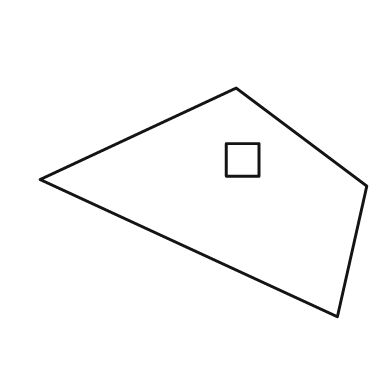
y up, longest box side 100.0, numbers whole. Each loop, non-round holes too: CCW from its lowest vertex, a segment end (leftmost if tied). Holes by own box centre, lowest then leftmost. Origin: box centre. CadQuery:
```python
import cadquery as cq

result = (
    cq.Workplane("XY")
    .moveTo(41.0, -35.0)
    .lineTo(50.0, 5.0)
    .lineTo(10.0, 35.0)
    .lineTo(-50.0, 7.0)
    .close()
    .moveTo(7.0, 8.0)
    .lineTo(17.0, 8.0)
    .lineTo(17.0, 18.0)
    .lineTo(7.0, 18.0)
    .close()
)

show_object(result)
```